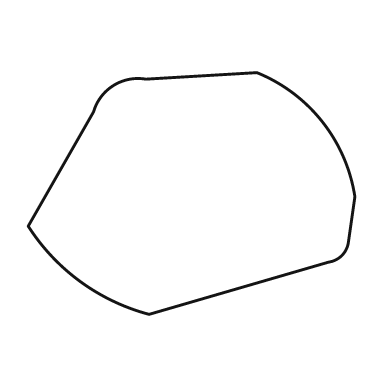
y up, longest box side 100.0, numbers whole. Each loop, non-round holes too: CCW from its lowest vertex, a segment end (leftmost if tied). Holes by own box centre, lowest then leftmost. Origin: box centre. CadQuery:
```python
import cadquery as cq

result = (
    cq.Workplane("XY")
    .moveTo(-13.0, -37.0)
    .lineTo(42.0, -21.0)
    .threePointArc((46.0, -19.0), (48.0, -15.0))
    .lineTo(50.0, -1.0)
    .threePointArc((40.0, 22.0), (20.0, 37.0))
    .lineTo(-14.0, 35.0)
    .threePointArc((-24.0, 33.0), (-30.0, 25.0))
    .lineTo(-50.0, -10.0)
    .threePointArc((-34.0, -27.0), (-13.0, -37.0))
    .close()
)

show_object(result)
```